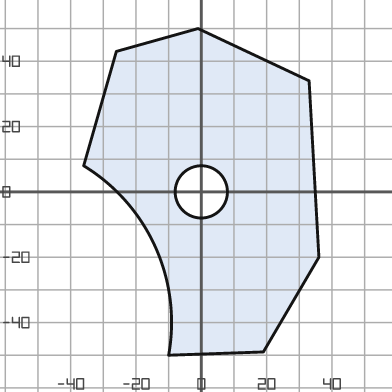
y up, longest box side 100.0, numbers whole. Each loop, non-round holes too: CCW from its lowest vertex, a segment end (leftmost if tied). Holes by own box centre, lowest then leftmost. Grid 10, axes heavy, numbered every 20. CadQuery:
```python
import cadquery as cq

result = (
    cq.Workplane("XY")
    .moveTo(-10.0, -50.0)
    .lineTo(19.0, -49.0)
    .lineTo(36.0, -20.0)
    .lineTo(33.0, 34.0)
    .lineTo(-1.0, 50.0)
    .lineTo(-26.0, 43.0)
    .lineTo(-36.0, 8.0)
    .threePointArc((-14.0, -17.0), (-10.0, -50.0))
    .close()
    .moveTo(0.0, 0.0)
    .circle(8.0)
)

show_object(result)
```